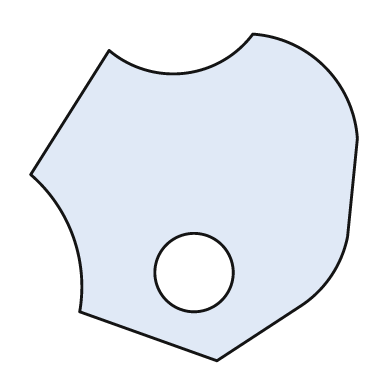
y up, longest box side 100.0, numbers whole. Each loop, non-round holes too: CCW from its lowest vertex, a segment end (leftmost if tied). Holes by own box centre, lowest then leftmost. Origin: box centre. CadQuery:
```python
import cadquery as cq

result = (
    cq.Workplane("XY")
    .moveTo(7.0, -50.0)
    .lineTo(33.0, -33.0)
    .threePointArc((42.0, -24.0), (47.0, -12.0))
    .lineTo(50.0, 18.0)
    .threePointArc((40.0, 40.0), (18.0, 50.0))
    .threePointArc((-3.0, 38.0), (-26.0, 45.0))
    .lineTo(-50.0, 7.0)
    .threePointArc((-37.0, -12.0), (-35.0, -35.0))
    .close()
    .moveTo(0.0, -23.0)
    .circle(12.0)
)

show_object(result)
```